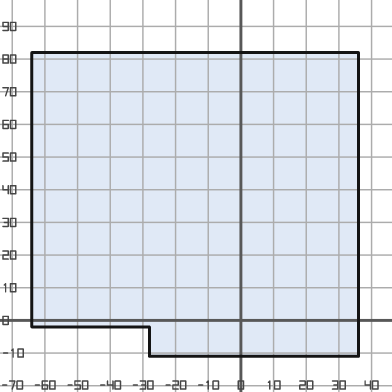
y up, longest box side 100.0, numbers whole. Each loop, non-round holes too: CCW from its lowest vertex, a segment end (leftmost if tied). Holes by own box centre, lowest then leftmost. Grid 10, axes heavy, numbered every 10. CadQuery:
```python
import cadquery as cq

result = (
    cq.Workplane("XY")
    .moveTo(-28.0, -11.0)
    .lineTo(36.0, -11.0)
    .lineTo(36.0, 82.0)
    .lineTo(-64.0, 82.0)
    .lineTo(-64.0, -2.0)
    .lineTo(-28.0, -2.0)
    .close()
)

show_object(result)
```